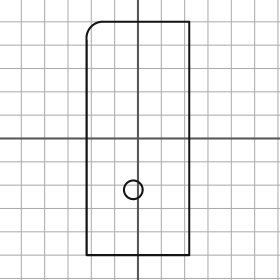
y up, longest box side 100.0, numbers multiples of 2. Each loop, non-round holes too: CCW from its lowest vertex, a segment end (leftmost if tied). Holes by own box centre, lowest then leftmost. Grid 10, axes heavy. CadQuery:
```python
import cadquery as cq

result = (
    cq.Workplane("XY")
    .moveTo(-22.0, -50.0)
    .lineTo(22.0, -50.0)
    .lineTo(22.0, 50.0)
    .lineTo(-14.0, 50.0)
    .threePointArc((-20.0, 48.0), (-22.0, 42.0))
    .close()
    .moveTo(-2.0, -22.0)
    .circle(4.0)
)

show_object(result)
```